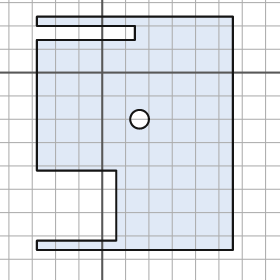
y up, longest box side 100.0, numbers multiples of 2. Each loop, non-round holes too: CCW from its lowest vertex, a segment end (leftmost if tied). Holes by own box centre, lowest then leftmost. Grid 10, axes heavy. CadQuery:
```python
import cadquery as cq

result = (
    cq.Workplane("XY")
    .moveTo(-28.0, -76.0)
    .lineTo(56.0, -76.0)
    .lineTo(56.0, 24.0)
    .lineTo(-28.0, 24.0)
    .lineTo(-28.0, 20.0)
    .lineTo(14.0, 20.0)
    .lineTo(14.0, 14.0)
    .lineTo(-28.0, 14.0)
    .lineTo(-28.0, -42.0)
    .lineTo(6.0, -42.0)
    .lineTo(6.0, -72.0)
    .lineTo(-28.0, -72.0)
    .close()
    .moveTo(16.0, -20.0)
    .circle(4.0)
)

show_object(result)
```